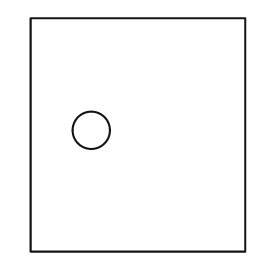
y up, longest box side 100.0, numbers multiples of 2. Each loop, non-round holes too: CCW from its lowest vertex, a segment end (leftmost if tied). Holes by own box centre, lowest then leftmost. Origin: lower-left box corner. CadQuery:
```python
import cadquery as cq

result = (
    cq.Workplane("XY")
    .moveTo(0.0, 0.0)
    .lineTo(92.0, 0.0)
    .lineTo(92.0, 100.0)
    .lineTo(0.0, 100.0)
    .close()
    .moveTo(26.0, 52.0)
    .circle(8.0)
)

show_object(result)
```